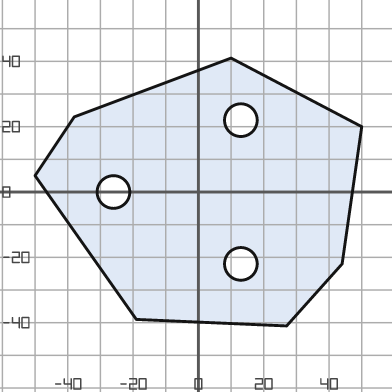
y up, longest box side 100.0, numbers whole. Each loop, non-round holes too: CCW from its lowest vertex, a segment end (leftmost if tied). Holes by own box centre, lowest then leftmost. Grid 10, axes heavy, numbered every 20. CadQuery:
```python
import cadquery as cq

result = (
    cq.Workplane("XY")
    .moveTo(27.0, -41.0)
    .lineTo(44.0, -22.0)
    .lineTo(50.0, 20.0)
    .lineTo(10.0, 41.0)
    .lineTo(-38.0, 23.0)
    .lineTo(-50.0, 5.0)
    .lineTo(-19.0, -39.0)
    .close()
    .moveTo(13.0, -22.0)
    .circle(5.0)
    .moveTo(-26.0, 0.0)
    .circle(5.0)
    .moveTo(13.0, 22.0)
    .circle(5.0)
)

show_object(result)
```